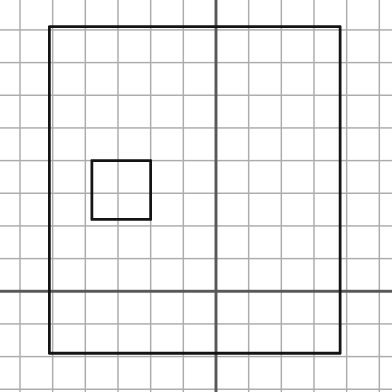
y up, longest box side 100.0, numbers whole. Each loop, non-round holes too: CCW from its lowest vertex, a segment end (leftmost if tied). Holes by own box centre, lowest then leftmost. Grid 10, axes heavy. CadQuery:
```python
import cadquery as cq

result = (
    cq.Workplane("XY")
    .moveTo(-51.0, -19.0)
    .lineTo(38.0, -19.0)
    .lineTo(38.0, 81.0)
    .lineTo(-51.0, 81.0)
    .close()
    .moveTo(-38.0, 22.0)
    .lineTo(-20.0, 22.0)
    .lineTo(-20.0, 40.0)
    .lineTo(-38.0, 40.0)
    .close()
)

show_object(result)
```